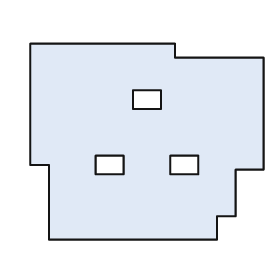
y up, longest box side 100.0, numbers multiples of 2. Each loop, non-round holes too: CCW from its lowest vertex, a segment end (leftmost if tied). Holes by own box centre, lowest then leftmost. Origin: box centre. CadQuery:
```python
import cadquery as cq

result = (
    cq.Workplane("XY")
    .moveTo(-42.0, -42.0)
    .lineTo(30.0, -42.0)
    .lineTo(30.0, -32.0)
    .lineTo(38.0, -32.0)
    .lineTo(38.0, -12.0)
    .lineTo(50.0, -12.0)
    .lineTo(50.0, 36.0)
    .lineTo(12.0, 36.0)
    .lineTo(12.0, 42.0)
    .lineTo(-50.0, 42.0)
    .lineTo(-50.0, -10.0)
    .lineTo(-42.0, -10.0)
    .close()
    .moveTo(-22.0, -14.0)
    .lineTo(-10.0, -14.0)
    .lineTo(-10.0, -6.0)
    .lineTo(-22.0, -6.0)
    .close()
    .moveTo(10.0, -14.0)
    .lineTo(22.0, -14.0)
    .lineTo(22.0, -6.0)
    .lineTo(10.0, -6.0)
    .close()
    .moveTo(-6.0, 14.0)
    .lineTo(6.0, 14.0)
    .lineTo(6.0, 22.0)
    .lineTo(-6.0, 22.0)
    .close()
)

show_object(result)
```